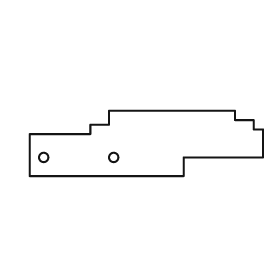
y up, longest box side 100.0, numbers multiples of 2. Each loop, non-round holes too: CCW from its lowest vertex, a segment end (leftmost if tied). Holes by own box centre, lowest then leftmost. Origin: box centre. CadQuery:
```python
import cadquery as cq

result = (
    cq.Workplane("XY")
    .moveTo(-50.0, -14.0)
    .lineTo(16.0, -14.0)
    .lineTo(16.0, -6.0)
    .lineTo(50.0, -6.0)
    .lineTo(50.0, 6.0)
    .lineTo(46.0, 6.0)
    .lineTo(46.0, 10.0)
    .lineTo(38.0, 10.0)
    .lineTo(38.0, 14.0)
    .lineTo(-16.0, 14.0)
    .lineTo(-16.0, 8.0)
    .lineTo(-24.0, 8.0)
    .lineTo(-24.0, 4.0)
    .lineTo(-50.0, 4.0)
    .close()
    .moveTo(-44.0, -6.0)
    .circle(2.0)
    .moveTo(-14.0, -6.0)
    .circle(2.0)
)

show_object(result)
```